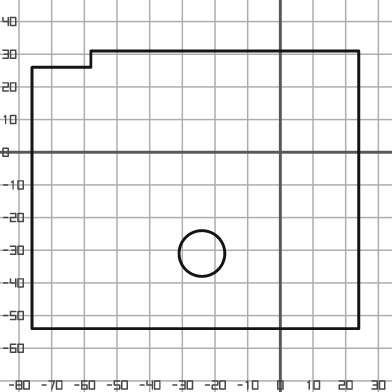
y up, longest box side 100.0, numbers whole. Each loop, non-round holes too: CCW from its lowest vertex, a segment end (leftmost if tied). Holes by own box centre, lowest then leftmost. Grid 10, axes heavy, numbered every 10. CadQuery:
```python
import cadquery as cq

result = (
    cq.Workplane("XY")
    .moveTo(-76.0, -54.0)
    .lineTo(24.0, -54.0)
    .lineTo(24.0, 31.0)
    .lineTo(-58.0, 31.0)
    .lineTo(-58.0, 26.0)
    .lineTo(-76.0, 26.0)
    .close()
    .moveTo(-24.0, -31.0)
    .circle(7.0)
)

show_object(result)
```